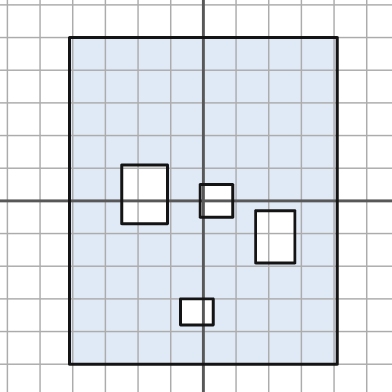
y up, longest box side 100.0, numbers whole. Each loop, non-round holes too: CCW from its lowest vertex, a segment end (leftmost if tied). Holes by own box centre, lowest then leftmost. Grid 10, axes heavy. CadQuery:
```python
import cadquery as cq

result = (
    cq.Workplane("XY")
    .moveTo(-41.0, -50.0)
    .lineTo(41.0, -50.0)
    .lineTo(41.0, 50.0)
    .lineTo(-41.0, 50.0)
    .close()
    .moveTo(-7.0, -38.0)
    .lineTo(3.0, -38.0)
    .lineTo(3.0, -30.0)
    .lineTo(-7.0, -30.0)
    .close()
    .moveTo(16.0, -19.0)
    .lineTo(28.0, -19.0)
    .lineTo(28.0, -3.0)
    .lineTo(16.0, -3.0)
    .close()
    .moveTo(-1.0, -5.0)
    .lineTo(9.0, -5.0)
    .lineTo(9.0, 5.0)
    .lineTo(-1.0, 5.0)
    .close()
    .moveTo(-25.0, -7.0)
    .lineTo(-11.0, -7.0)
    .lineTo(-11.0, 11.0)
    .lineTo(-25.0, 11.0)
    .close()
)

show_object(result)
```